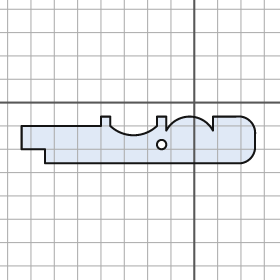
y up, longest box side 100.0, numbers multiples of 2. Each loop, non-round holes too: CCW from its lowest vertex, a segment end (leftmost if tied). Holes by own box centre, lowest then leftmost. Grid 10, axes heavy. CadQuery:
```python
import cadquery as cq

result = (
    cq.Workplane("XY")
    .moveTo(-64.0, -26.0)
    .lineTo(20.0, -26.0)
    .threePointArc((24.0, -24.0), (26.0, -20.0))
    .lineTo(26.0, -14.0)
    .threePointArc((24.0, -8.0), (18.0, -6.0))
    .lineTo(8.0, -6.0)
    .lineTo(8.0, -12.0)
    .threePointArc((-2.0, -6.0), (-12.0, -12.0))
    .lineTo(-12.0, -6.0)
    .lineTo(-16.0, -6.0)
    .lineTo(-16.0, -10.0)
    .threePointArc((-26.0, -14.0), (-36.0, -10.0))
    .lineTo(-36.0, -6.0)
    .lineTo(-40.0, -6.0)
    .lineTo(-40.0, -10.0)
    .lineTo(-74.0, -10.0)
    .lineTo(-74.0, -20.0)
    .lineTo(-64.0, -20.0)
    .close()
    .moveTo(-14.0, -18.0)
    .circle(2.0)
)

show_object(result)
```